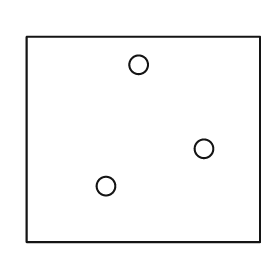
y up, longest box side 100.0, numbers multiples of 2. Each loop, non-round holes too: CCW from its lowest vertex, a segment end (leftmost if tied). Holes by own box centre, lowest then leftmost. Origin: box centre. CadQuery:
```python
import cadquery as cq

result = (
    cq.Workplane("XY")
    .moveTo(-50.0, -44.0)
    .lineTo(50.0, -44.0)
    .lineTo(50.0, 44.0)
    .lineTo(-50.0, 44.0)
    .close()
    .moveTo(-16.0, -20.0)
    .circle(4.0)
    .moveTo(26.0, -4.0)
    .circle(4.0)
    .moveTo(-2.0, 32.0)
    .circle(4.0)
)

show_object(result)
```